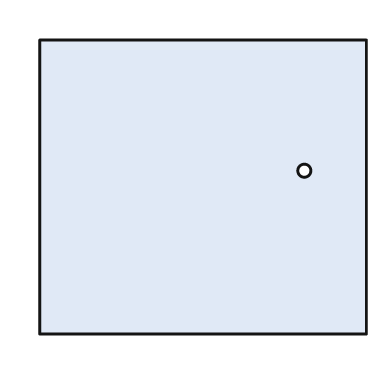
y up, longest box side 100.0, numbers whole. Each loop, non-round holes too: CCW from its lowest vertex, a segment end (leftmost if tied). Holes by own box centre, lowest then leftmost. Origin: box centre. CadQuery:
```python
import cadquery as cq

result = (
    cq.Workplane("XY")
    .moveTo(-50.0, -45.0)
    .lineTo(50.0, -45.0)
    .lineTo(50.0, 45.0)
    .lineTo(-50.0, 45.0)
    .close()
    .moveTo(31.0, 5.0)
    .circle(2.0)
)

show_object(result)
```